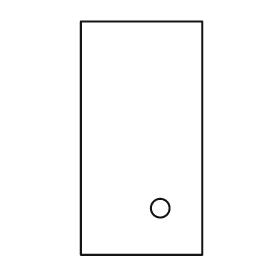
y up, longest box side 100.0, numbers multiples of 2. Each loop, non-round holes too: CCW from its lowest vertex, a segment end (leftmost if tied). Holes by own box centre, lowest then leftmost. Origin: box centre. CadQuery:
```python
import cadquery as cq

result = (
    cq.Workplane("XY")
    .moveTo(-26.0, -50.0)
    .lineTo(26.0, -50.0)
    .lineTo(26.0, 50.0)
    .lineTo(-26.0, 50.0)
    .close()
    .moveTo(8.0, -30.0)
    .circle(4.0)
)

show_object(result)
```